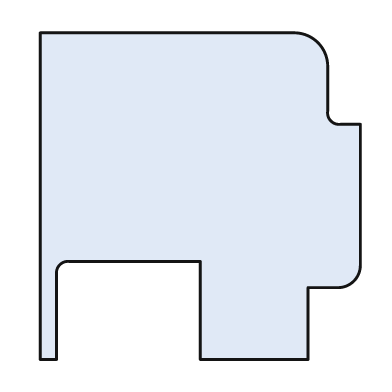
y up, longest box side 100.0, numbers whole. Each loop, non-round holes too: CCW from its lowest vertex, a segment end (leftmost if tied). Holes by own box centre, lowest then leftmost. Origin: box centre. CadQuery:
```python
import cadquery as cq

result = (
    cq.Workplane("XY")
    .moveTo(-49.0, -50.0)
    .lineTo(-44.0, -50.0)
    .lineTo(-44.0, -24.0)
    .threePointArc((-43.0, -21.0), (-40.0, -20.0))
    .lineTo(0.0, -20.0)
    .lineTo(0.0, -50.0)
    .lineTo(33.0, -50.0)
    .lineTo(33.0, -28.0)
    .lineTo(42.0, -28.0)
    .threePointArc((47.0, -26.0), (49.0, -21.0))
    .lineTo(49.0, 22.0)
    .lineTo(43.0, 22.0)
    .threePointArc((40.0, 23.0), (39.0, 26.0))
    .lineTo(39.0, 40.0)
    .threePointArc((36.0, 47.0), (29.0, 50.0))
    .lineTo(-49.0, 50.0)
    .close()
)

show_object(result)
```